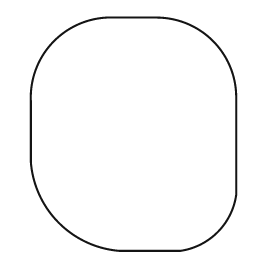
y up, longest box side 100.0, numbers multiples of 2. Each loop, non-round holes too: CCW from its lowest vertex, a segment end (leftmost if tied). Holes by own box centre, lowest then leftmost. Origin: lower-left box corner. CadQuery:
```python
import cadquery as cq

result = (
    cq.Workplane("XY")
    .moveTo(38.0, 0.0)
    .lineTo(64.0, 0.0)
    .threePointArc((80.0, 8.0), (88.0, 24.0))
    .lineTo(88.0, 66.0)
    .threePointArc((78.0, 90.0), (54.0, 100.0))
    .lineTo(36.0, 100.0)
    .threePointArc((10.0, 90.0), (0.0, 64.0))
    .lineTo(0.0, 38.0)
    .threePointArc((12.0, 12.0), (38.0, 0.0))
    .close()
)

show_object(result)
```